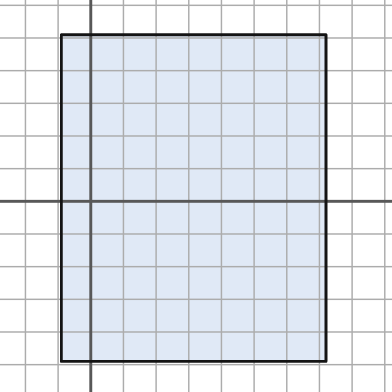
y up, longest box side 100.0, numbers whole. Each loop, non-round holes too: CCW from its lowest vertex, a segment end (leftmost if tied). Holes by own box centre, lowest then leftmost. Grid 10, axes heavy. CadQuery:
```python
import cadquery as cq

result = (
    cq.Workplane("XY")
    .moveTo(-9.0, -49.0)
    .lineTo(72.0, -49.0)
    .lineTo(72.0, 51.0)
    .lineTo(-9.0, 51.0)
    .close()
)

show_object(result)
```